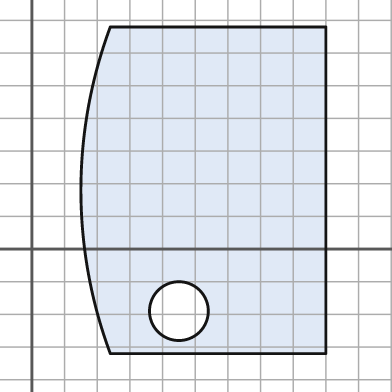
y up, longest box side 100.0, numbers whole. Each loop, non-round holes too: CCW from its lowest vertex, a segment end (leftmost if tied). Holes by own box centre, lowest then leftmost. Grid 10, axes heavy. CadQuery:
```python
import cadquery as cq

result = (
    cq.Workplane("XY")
    .moveTo(24.0, -32.0)
    .lineTo(90.0, -32.0)
    .lineTo(90.0, 68.0)
    .lineTo(24.0, 68.0)
    .threePointArc((15.0, 18.0), (24.0, -32.0))
    .close()
    .moveTo(45.0, -19.0)
    .circle(9.0)
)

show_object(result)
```